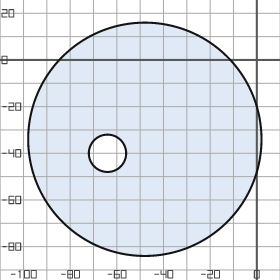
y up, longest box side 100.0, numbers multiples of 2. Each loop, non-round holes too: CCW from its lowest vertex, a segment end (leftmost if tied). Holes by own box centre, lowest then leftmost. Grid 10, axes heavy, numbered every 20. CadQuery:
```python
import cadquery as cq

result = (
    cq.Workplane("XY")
    .moveTo(-48.0, -34.0)
    .circle(50.0)
    .moveTo(-64.0, -40.0)
    .circle(8.0)
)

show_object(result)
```